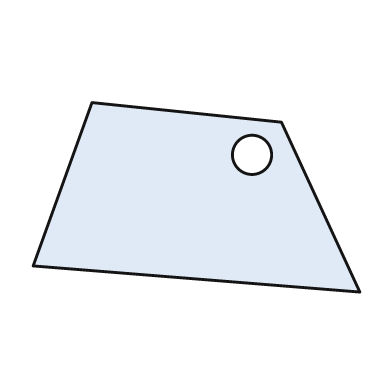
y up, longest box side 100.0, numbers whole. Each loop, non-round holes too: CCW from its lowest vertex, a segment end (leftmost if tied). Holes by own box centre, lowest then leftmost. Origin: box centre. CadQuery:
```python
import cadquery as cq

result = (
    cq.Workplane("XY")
    .moveTo(50.0, -29.0)
    .lineTo(26.0, 23.0)
    .lineTo(-32.0, 29.0)
    .lineTo(-50.0, -21.0)
    .close()
    .moveTo(17.0, 13.0)
    .circle(6.0)
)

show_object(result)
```